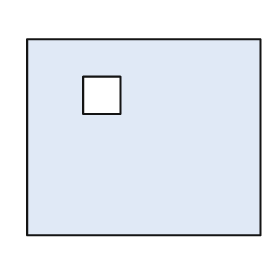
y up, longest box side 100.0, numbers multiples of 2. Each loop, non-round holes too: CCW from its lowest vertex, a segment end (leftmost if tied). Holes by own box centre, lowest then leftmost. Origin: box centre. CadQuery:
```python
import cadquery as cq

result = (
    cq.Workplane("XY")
    .moveTo(-50.0, -42.0)
    .lineTo(50.0, -42.0)
    .lineTo(50.0, 42.0)
    .lineTo(-50.0, 42.0)
    .close()
    .moveTo(-26.0, 10.0)
    .lineTo(-10.0, 10.0)
    .lineTo(-10.0, 26.0)
    .lineTo(-26.0, 26.0)
    .close()
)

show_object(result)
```